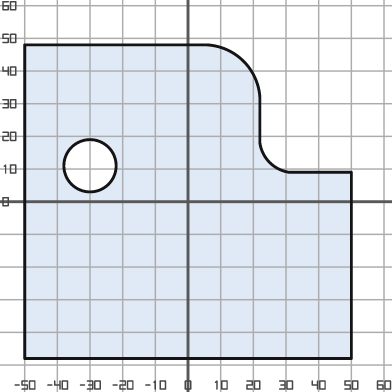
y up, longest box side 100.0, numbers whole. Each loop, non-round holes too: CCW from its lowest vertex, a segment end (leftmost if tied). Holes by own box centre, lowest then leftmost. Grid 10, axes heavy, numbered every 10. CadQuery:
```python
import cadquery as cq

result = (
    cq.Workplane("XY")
    .moveTo(-50.0, -48.0)
    .lineTo(50.0, -48.0)
    .lineTo(50.0, 9.0)
    .lineTo(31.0, 9.0)
    .threePointArc((25.0, 12.0), (22.0, 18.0))
    .lineTo(22.0, 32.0)
    .threePointArc((17.0, 43.0), (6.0, 48.0))
    .lineTo(-50.0, 48.0)
    .close()
    .moveTo(-30.0, 11.0)
    .circle(8.0)
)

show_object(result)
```